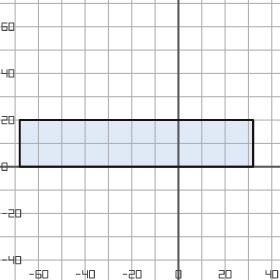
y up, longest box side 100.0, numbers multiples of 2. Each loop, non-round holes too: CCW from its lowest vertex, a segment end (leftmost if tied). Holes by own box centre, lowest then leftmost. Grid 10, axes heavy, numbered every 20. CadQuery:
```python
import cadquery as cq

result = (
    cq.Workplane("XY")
    .moveTo(-68.0, 0.0)
    .lineTo(32.0, 0.0)
    .lineTo(32.0, 20.0)
    .lineTo(-68.0, 20.0)
    .close()
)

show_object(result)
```